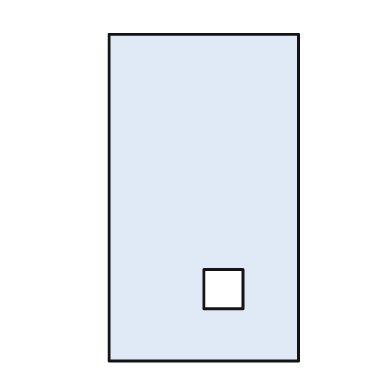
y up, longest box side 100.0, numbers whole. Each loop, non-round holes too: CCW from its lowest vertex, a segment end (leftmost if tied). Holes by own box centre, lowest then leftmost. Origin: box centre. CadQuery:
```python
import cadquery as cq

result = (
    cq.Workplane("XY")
    .moveTo(-29.0, -50.0)
    .lineTo(29.0, -50.0)
    .lineTo(29.0, 50.0)
    .lineTo(-29.0, 50.0)
    .close()
    .moveTo(0.0, -34.0)
    .lineTo(12.0, -34.0)
    .lineTo(12.0, -22.0)
    .lineTo(0.0, -22.0)
    .close()
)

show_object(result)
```